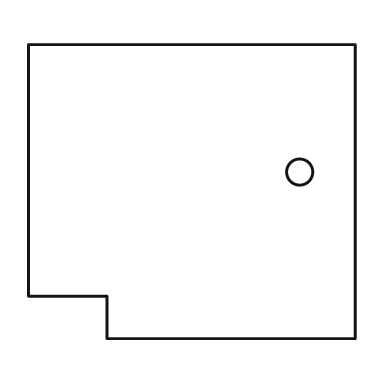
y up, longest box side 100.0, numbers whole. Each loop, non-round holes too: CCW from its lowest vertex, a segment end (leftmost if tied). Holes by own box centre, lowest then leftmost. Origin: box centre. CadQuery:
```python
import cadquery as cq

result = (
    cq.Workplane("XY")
    .moveTo(-26.0, -45.0)
    .lineTo(50.0, -45.0)
    .lineTo(50.0, 45.0)
    .lineTo(-50.0, 45.0)
    .lineTo(-50.0, -32.0)
    .lineTo(-26.0, -32.0)
    .close()
    .moveTo(33.0, 6.0)
    .circle(4.0)
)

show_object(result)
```